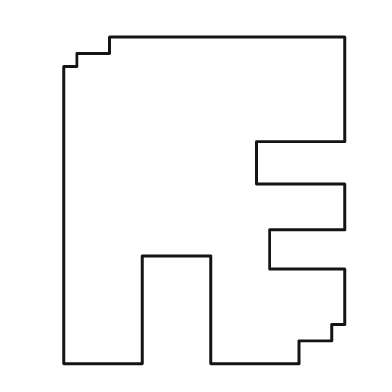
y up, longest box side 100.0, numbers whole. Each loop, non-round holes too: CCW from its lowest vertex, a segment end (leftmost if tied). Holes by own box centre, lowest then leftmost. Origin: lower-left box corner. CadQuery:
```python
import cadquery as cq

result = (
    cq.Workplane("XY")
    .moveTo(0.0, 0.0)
    .lineTo(24.0, 0.0)
    .lineTo(24.0, 33.0)
    .lineTo(45.0, 33.0)
    .lineTo(45.0, 0.0)
    .lineTo(72.0, 0.0)
    .lineTo(72.0, 7.0)
    .lineTo(82.0, 7.0)
    .lineTo(82.0, 12.0)
    .lineTo(86.0, 12.0)
    .lineTo(86.0, 29.0)
    .lineTo(63.0, 29.0)
    .lineTo(63.0, 41.0)
    .lineTo(86.0, 41.0)
    .lineTo(86.0, 55.0)
    .lineTo(59.0, 55.0)
    .lineTo(59.0, 68.0)
    .lineTo(86.0, 68.0)
    .lineTo(86.0, 100.0)
    .lineTo(14.0, 100.0)
    .lineTo(14.0, 95.0)
    .lineTo(4.0, 95.0)
    .lineTo(4.0, 91.0)
    .lineTo(0.0, 91.0)
    .close()
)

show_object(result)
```